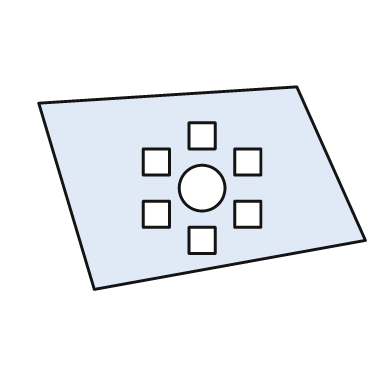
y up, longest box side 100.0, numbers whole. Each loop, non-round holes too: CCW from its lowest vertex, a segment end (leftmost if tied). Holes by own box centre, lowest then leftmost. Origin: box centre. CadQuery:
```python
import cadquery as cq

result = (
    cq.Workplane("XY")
    .moveTo(-33.0, -31.0)
    .lineTo(50.0, -16.0)
    .lineTo(29.0, 31.0)
    .lineTo(-50.0, 26.0)
    .close()
    .moveTo(-4.0, -20.0)
    .lineTo(4.0, -20.0)
    .lineTo(4.0, -12.0)
    .lineTo(-4.0, -12.0)
    .close()
    .moveTo(-18.0, -12.0)
    .lineTo(-10.0, -12.0)
    .lineTo(-10.0, -4.0)
    .lineTo(-18.0, -4.0)
    .close()
    .moveTo(10.0, -12.0)
    .lineTo(18.0, -12.0)
    .lineTo(18.0, -4.0)
    .lineTo(10.0, -4.0)
    .close()
    .moveTo(0.0, 0.0)
    .circle(7.0)
    .moveTo(-18.0, 4.0)
    .lineTo(-10.0, 4.0)
    .lineTo(-10.0, 12.0)
    .lineTo(-18.0, 12.0)
    .close()
    .moveTo(10.0, 4.0)
    .lineTo(18.0, 4.0)
    .lineTo(18.0, 12.0)
    .lineTo(10.0, 12.0)
    .close()
    .moveTo(-4.0, 12.0)
    .lineTo(4.0, 12.0)
    .lineTo(4.0, 20.0)
    .lineTo(-4.0, 20.0)
    .close()
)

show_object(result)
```